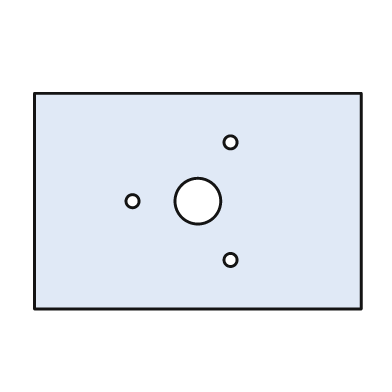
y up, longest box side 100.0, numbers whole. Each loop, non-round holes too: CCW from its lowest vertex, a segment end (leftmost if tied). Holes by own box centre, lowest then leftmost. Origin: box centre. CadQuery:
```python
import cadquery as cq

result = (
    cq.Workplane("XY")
    .moveTo(-50.0, -33.0)
    .lineTo(50.0, -33.0)
    .lineTo(50.0, 33.0)
    .lineTo(-50.0, 33.0)
    .close()
    .moveTo(10.0, -18.0)
    .circle(2.0)
    .moveTo(-20.0, 0.0)
    .circle(2.0)
    .moveTo(0.0, 0.0)
    .circle(7.0)
    .moveTo(10.0, 18.0)
    .circle(2.0)
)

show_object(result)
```